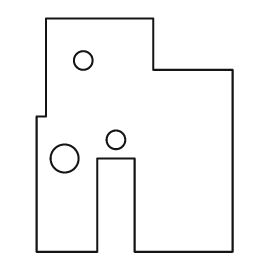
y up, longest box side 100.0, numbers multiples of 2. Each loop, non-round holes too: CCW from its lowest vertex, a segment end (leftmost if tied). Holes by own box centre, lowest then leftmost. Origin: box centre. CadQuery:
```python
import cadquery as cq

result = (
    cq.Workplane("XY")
    .moveTo(-42.0, -50.0)
    .lineTo(-16.0, -50.0)
    .lineTo(-16.0, -10.0)
    .lineTo(0.0, -10.0)
    .lineTo(0.0, -50.0)
    .lineTo(42.0, -50.0)
    .lineTo(42.0, 28.0)
    .lineTo(8.0, 28.0)
    .lineTo(8.0, 50.0)
    .lineTo(-38.0, 50.0)
    .lineTo(-38.0, 8.0)
    .lineTo(-42.0, 8.0)
    .close()
    .moveTo(-30.0, -10.0)
    .circle(6.0)
    .moveTo(-8.0, -2.0)
    .circle(4.0)
    .moveTo(-22.0, 32.0)
    .circle(4.0)
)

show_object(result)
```